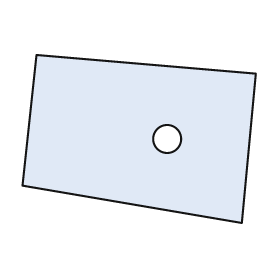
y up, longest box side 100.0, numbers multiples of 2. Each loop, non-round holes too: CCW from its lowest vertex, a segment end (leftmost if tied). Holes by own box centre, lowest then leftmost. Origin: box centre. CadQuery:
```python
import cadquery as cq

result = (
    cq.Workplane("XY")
    .moveTo(44.0, -36.0)
    .lineTo(50.0, 28.0)
    .lineTo(-44.0, 36.0)
    .lineTo(-50.0, -20.0)
    .close()
    .moveTo(12.0, 0.0)
    .circle(6.0)
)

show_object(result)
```